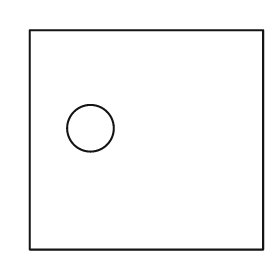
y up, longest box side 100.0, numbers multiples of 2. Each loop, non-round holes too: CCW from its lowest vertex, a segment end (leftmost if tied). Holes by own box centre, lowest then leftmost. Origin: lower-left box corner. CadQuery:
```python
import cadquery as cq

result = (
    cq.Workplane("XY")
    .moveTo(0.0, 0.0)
    .lineTo(100.0, 0.0)
    .lineTo(100.0, 94.0)
    .lineTo(0.0, 94.0)
    .close()
    .moveTo(26.0, 52.0)
    .circle(10.0)
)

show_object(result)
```